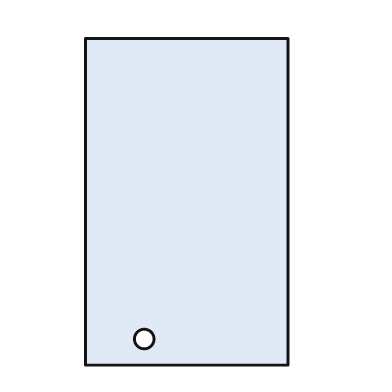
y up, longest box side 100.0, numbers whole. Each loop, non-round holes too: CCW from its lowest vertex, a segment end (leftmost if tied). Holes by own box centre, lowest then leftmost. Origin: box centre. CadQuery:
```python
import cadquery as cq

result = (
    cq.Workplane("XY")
    .moveTo(-31.0, -50.0)
    .lineTo(31.0, -50.0)
    .lineTo(31.0, 50.0)
    .lineTo(-31.0, 50.0)
    .close()
    .moveTo(-13.0, -42.0)
    .circle(3.0)
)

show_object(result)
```